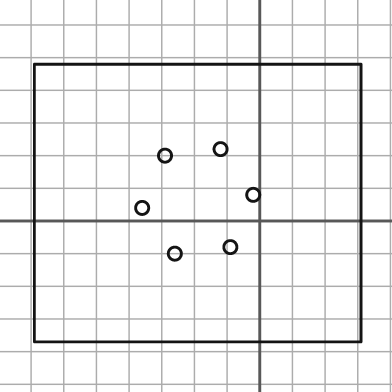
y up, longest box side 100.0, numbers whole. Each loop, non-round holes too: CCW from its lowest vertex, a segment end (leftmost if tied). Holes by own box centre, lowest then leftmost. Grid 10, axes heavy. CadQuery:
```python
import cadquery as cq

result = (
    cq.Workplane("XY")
    .moveTo(-69.0, -37.0)
    .lineTo(31.0, -37.0)
    .lineTo(31.0, 48.0)
    .lineTo(-69.0, 48.0)
    .close()
    .moveTo(-26.0, -10.0)
    .circle(2.0)
    .moveTo(-9.0, -8.0)
    .circle(2.0)
    .moveTo(-36.0, 4.0)
    .circle(2.0)
    .moveTo(-2.0, 8.0)
    .circle(2.0)
    .moveTo(-29.0, 20.0)
    .circle(2.0)
    .moveTo(-12.0, 22.0)
    .circle(2.0)
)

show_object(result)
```